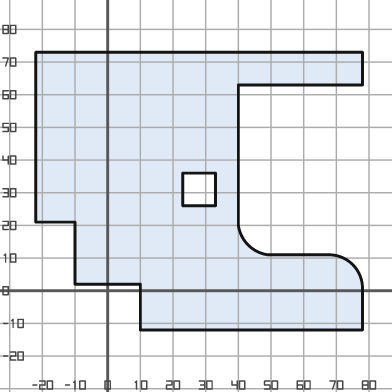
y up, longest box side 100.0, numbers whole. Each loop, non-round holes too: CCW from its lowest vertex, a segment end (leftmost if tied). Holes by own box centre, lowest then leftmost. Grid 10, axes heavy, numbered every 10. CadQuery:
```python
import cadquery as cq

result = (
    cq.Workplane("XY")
    .moveTo(10.0, -12.0)
    .lineTo(78.0, -12.0)
    .lineTo(78.0, 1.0)
    .threePointArc((75.0, 8.0), (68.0, 11.0))
    .lineTo(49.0, 11.0)
    .threePointArc((43.0, 14.0), (40.0, 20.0))
    .lineTo(40.0, 63.0)
    .lineTo(78.0, 63.0)
    .lineTo(78.0, 73.0)
    .lineTo(-22.0, 73.0)
    .lineTo(-22.0, 21.0)
    .lineTo(-10.0, 21.0)
    .lineTo(-10.0, 2.0)
    .lineTo(10.0, 2.0)
    .close()
    .moveTo(23.0, 26.0)
    .lineTo(33.0, 26.0)
    .lineTo(33.0, 36.0)
    .lineTo(23.0, 36.0)
    .close()
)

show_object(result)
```